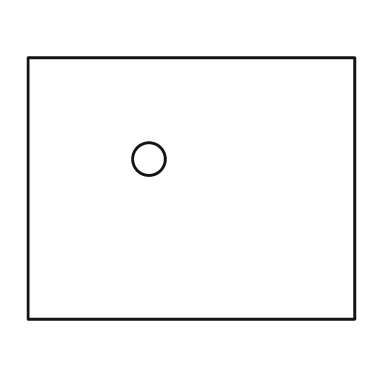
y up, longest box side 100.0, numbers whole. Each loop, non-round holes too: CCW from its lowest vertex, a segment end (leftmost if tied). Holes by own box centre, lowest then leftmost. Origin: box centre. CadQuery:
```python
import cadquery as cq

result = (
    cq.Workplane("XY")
    .moveTo(-50.0, -40.0)
    .lineTo(50.0, -40.0)
    .lineTo(50.0, 40.0)
    .lineTo(-50.0, 40.0)
    .close()
    .moveTo(-13.0, 9.0)
    .circle(5.0)
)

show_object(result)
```